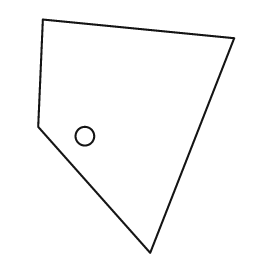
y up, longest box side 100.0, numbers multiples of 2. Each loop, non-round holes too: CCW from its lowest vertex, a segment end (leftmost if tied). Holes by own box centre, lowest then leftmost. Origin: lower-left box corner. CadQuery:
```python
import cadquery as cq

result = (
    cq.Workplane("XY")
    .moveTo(48.0, 0.0)
    .lineTo(84.0, 92.0)
    .lineTo(2.0, 100.0)
    .lineTo(0.0, 54.0)
    .close()
    .moveTo(20.0, 50.0)
    .circle(4.0)
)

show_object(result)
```